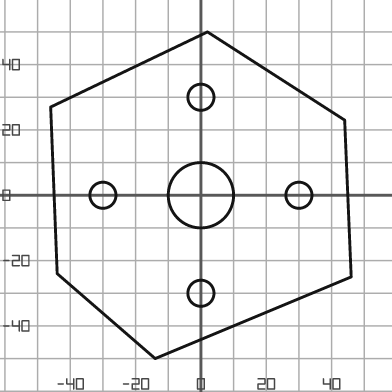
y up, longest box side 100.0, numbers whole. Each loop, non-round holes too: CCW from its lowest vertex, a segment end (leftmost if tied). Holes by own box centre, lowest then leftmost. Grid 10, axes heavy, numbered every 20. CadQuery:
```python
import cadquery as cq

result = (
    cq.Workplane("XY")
    .moveTo(-14.0, -50.0)
    .lineTo(46.0, -25.0)
    .lineTo(44.0, 23.0)
    .lineTo(2.0, 50.0)
    .lineTo(-46.0, 27.0)
    .lineTo(-44.0, -24.0)
    .close()
    .moveTo(0.0, -30.0)
    .circle(4.0)
    .moveTo(-30.0, 0.0)
    .circle(4.0)
    .moveTo(0.0, 0.0)
    .circle(10.0)
    .moveTo(30.0, 0.0)
    .circle(4.0)
    .moveTo(0.0, 30.0)
    .circle(4.0)
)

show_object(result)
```